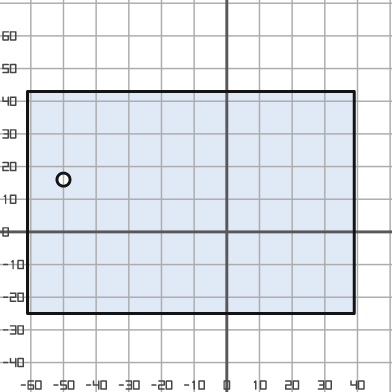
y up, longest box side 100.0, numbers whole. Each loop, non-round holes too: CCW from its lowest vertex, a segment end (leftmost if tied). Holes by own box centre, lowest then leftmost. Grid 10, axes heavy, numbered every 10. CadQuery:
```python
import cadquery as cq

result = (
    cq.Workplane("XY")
    .moveTo(-61.0, -25.0)
    .lineTo(39.0, -25.0)
    .lineTo(39.0, 43.0)
    .lineTo(-61.0, 43.0)
    .close()
    .moveTo(-50.0, 16.0)
    .circle(2.0)
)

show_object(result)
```